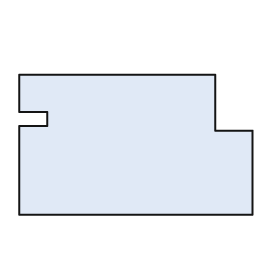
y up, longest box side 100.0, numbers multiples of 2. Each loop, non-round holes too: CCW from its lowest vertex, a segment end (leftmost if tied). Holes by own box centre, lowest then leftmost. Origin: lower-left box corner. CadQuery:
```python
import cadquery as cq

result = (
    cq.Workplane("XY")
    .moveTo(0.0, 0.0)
    .lineTo(100.0, 0.0)
    .lineTo(100.0, 36.0)
    .lineTo(84.0, 36.0)
    .lineTo(84.0, 60.0)
    .lineTo(0.0, 60.0)
    .lineTo(0.0, 44.0)
    .lineTo(12.0, 44.0)
    .lineTo(12.0, 38.0)
    .lineTo(0.0, 38.0)
    .close()
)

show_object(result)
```